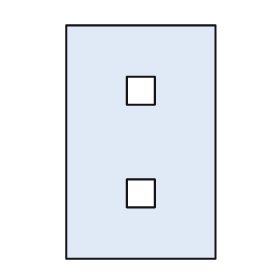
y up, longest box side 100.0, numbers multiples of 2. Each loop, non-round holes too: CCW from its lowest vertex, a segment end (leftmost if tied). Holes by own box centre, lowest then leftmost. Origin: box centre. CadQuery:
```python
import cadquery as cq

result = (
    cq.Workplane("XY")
    .moveTo(-32.0, -50.0)
    .lineTo(32.0, -50.0)
    .lineTo(32.0, 50.0)
    .lineTo(-32.0, 50.0)
    .close()
    .moveTo(-6.0, -28.0)
    .lineTo(6.0, -28.0)
    .lineTo(6.0, -16.0)
    .lineTo(-6.0, -16.0)
    .close()
    .moveTo(-6.0, 16.0)
    .lineTo(6.0, 16.0)
    .lineTo(6.0, 28.0)
    .lineTo(-6.0, 28.0)
    .close()
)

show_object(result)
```